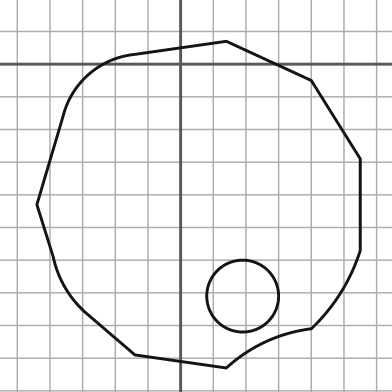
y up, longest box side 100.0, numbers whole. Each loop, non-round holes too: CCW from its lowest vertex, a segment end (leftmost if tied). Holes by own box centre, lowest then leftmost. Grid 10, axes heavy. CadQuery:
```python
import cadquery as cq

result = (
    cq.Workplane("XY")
    .moveTo(14.0, -93.0)
    .threePointArc((26.0, -85.0), (40.0, -81.0))
    .threePointArc((49.0, -70.0), (55.0, -57.0))
    .lineTo(55.0, -29.0)
    .lineTo(40.0, -5.0)
    .lineTo(14.0, 7.0)
    .lineTo(-14.0, 3.0)
    .threePointArc((-28.0, -3.0), (-36.0, -16.0))
    .lineTo(-44.0, -43.0)
    .lineTo(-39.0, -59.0)
    .threePointArc((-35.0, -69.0), (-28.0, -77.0))
    .lineTo(-14.0, -89.0)
    .close()
    .moveTo(19.0, -71.0)
    .circle(11.0)
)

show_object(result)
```